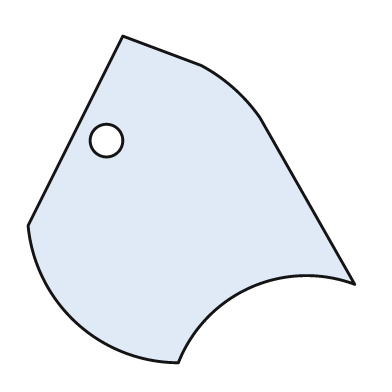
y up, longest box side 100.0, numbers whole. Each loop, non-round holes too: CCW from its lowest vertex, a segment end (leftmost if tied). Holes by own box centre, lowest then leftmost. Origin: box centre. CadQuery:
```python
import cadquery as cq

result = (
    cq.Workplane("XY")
    .moveTo(-4.0, -50.0)
    .threePointArc((18.0, -27.0), (50.0, -26.0))
    .lineTo(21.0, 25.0)
    .threePointArc((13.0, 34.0), (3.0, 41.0))
    .lineTo(-21.0, 50.0)
    .lineTo(-50.0, -8.0)
    .threePointArc((-35.0, -38.0), (-4.0, -50.0))
    .close()
    .moveTo(-26.0, 18.0)
    .circle(5.0)
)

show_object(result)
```